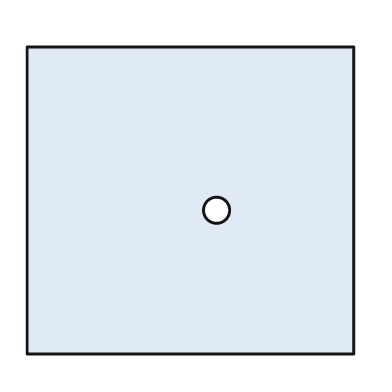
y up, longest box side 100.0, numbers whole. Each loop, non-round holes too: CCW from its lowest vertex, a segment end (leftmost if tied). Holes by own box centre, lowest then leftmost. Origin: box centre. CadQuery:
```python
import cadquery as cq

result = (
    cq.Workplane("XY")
    .moveTo(-50.0, -47.0)
    .lineTo(50.0, -47.0)
    .lineTo(50.0, 47.0)
    .lineTo(-50.0, 47.0)
    .close()
    .moveTo(8.0, -3.0)
    .circle(4.0)
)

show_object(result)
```